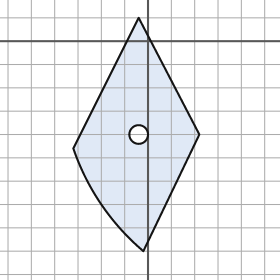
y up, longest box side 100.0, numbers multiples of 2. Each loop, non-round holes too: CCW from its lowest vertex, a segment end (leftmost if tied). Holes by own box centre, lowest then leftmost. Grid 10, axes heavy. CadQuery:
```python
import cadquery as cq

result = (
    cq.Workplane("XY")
    .moveTo(-2.0, -90.0)
    .lineTo(22.0, -40.0)
    .lineTo(-4.0, 10.0)
    .lineTo(-32.0, -46.0)
    .threePointArc((-20.0, -70.0), (-2.0, -90.0))
    .close()
    .moveTo(-4.0, -40.0)
    .circle(4.0)
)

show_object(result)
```